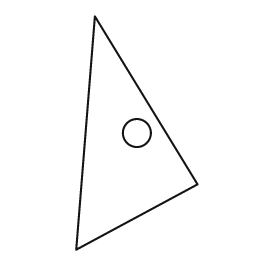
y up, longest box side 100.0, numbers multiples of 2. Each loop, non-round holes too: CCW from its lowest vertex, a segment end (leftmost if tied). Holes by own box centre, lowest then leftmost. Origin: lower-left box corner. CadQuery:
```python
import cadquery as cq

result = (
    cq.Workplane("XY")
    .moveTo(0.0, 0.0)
    .lineTo(52.0, 28.0)
    .lineTo(8.0, 100.0)
    .close()
    .moveTo(26.0, 50.0)
    .circle(6.0)
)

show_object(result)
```